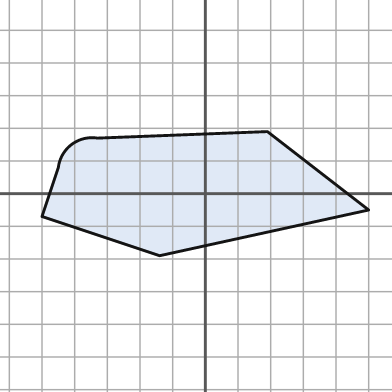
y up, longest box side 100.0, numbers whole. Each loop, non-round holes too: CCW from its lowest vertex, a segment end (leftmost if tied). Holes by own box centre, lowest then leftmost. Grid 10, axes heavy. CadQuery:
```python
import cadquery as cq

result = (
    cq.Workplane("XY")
    .moveTo(-14.0, -19.0)
    .lineTo(50.0, -5.0)
    .lineTo(19.0, 19.0)
    .lineTo(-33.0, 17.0)
    .threePointArc((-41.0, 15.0), (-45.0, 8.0))
    .lineTo(-50.0, -7.0)
    .close()
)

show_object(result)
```